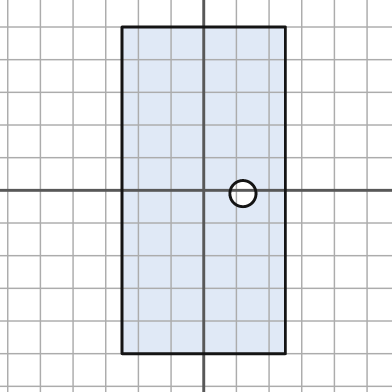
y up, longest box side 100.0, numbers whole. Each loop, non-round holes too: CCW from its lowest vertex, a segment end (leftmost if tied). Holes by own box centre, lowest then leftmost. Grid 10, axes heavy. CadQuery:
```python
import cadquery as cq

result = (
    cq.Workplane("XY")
    .moveTo(-25.0, -50.0)
    .lineTo(25.0, -50.0)
    .lineTo(25.0, 50.0)
    .lineTo(-25.0, 50.0)
    .close()
    .moveTo(12.0, -1.0)
    .circle(4.0)
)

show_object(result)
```